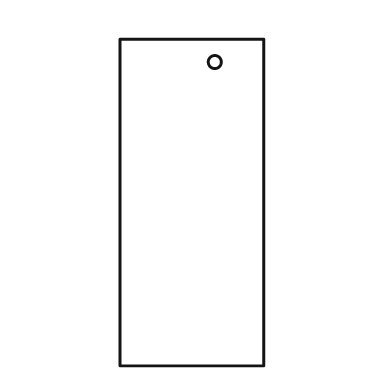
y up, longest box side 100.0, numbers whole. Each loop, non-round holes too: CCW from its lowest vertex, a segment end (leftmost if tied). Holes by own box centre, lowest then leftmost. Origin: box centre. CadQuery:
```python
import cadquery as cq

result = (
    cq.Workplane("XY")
    .moveTo(-22.0, -50.0)
    .lineTo(22.0, -50.0)
    .lineTo(22.0, 50.0)
    .lineTo(-22.0, 50.0)
    .close()
    .moveTo(7.0, 43.0)
    .circle(2.0)
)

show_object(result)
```